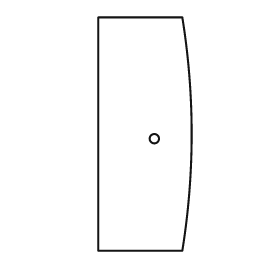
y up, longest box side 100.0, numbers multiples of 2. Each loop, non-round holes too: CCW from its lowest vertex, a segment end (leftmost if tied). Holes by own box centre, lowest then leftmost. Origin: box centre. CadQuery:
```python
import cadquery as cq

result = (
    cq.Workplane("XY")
    .moveTo(-20.0, -50.0)
    .lineTo(16.0, -50.0)
    .threePointArc((20.0, 0.0), (16.0, 50.0))
    .lineTo(-20.0, 50.0)
    .close()
    .moveTo(4.0, -2.0)
    .circle(2.0)
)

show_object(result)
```